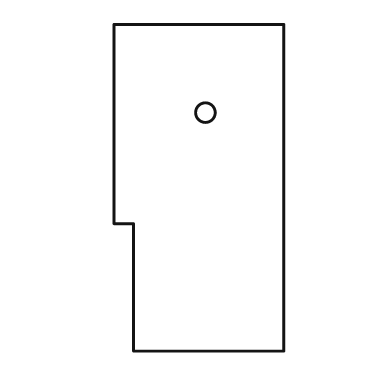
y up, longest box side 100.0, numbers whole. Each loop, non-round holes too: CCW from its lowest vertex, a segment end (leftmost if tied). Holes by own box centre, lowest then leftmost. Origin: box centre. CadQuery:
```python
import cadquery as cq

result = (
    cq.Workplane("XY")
    .moveTo(-20.0, -50.0)
    .lineTo(26.0, -50.0)
    .lineTo(26.0, 50.0)
    .lineTo(-26.0, 50.0)
    .lineTo(-26.0, -11.0)
    .lineTo(-20.0, -11.0)
    .close()
    .moveTo(2.0, 23.0)
    .circle(3.0)
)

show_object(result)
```